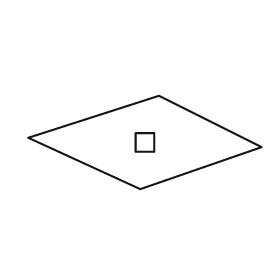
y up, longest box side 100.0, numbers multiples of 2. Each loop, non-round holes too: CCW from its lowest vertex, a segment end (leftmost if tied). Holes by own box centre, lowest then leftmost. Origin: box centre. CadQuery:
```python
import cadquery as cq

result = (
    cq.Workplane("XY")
    .moveTo(-2.0, -20.0)
    .lineTo(50.0, -2.0)
    .lineTo(6.0, 20.0)
    .lineTo(-50.0, 2.0)
    .close()
    .moveTo(-4.0, -4.0)
    .lineTo(4.0, -4.0)
    .lineTo(4.0, 4.0)
    .lineTo(-4.0, 4.0)
    .close()
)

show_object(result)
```